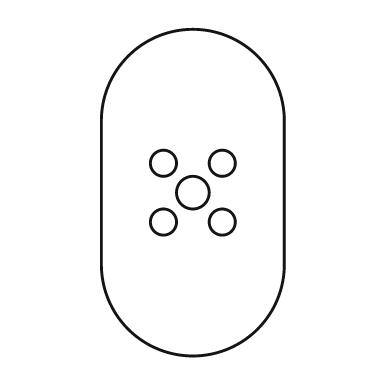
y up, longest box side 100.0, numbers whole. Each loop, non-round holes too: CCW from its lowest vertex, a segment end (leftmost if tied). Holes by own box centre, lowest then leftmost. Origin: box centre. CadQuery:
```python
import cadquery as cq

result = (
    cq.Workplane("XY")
    .moveTo(-28.0, -22.0)
    .threePointArc((0.0, -50.0), (28.0, -22.0))
    .lineTo(28.0, 22.0)
    .threePointArc((0.0, 50.0), (-28.0, 22.0))
    .close()
    .moveTo(-9.0, -9.0)
    .circle(4.0)
    .moveTo(9.0, -9.0)
    .circle(4.0)
    .moveTo(0.0, 0.0)
    .circle(5.0)
    .moveTo(-9.0, 9.0)
    .circle(4.0)
    .moveTo(9.0, 9.0)
    .circle(4.0)
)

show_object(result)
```